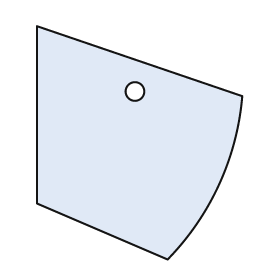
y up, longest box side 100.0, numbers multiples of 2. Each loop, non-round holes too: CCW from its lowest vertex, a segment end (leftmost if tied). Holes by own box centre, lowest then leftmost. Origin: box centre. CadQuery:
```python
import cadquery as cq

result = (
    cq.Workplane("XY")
    .moveTo(12.0, -50.0)
    .threePointArc((34.0, -18.0), (44.0, 20.0))
    .lineTo(-44.0, 50.0)
    .lineTo(-44.0, -26.0)
    .close()
    .moveTo(-2.0, 22.0)
    .circle(4.0)
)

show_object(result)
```